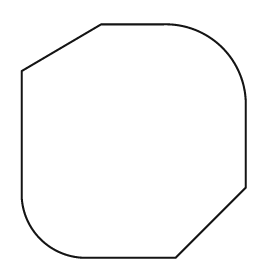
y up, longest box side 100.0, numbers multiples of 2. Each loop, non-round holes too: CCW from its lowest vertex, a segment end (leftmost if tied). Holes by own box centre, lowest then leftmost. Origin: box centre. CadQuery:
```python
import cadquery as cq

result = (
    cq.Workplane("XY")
    .moveTo(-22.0, -50.0)
    .lineTo(18.0, -50.0)
    .lineTo(48.0, -20.0)
    .lineTo(48.0, 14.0)
    .threePointArc((38.0, 40.0), (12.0, 50.0))
    .lineTo(-14.0, 50.0)
    .lineTo(-48.0, 30.0)
    .lineTo(-48.0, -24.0)
    .threePointArc((-40.0, -42.0), (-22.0, -50.0))
    .close()
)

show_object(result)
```